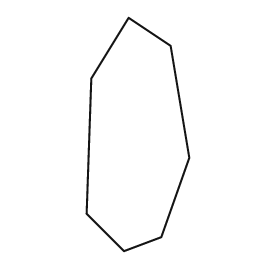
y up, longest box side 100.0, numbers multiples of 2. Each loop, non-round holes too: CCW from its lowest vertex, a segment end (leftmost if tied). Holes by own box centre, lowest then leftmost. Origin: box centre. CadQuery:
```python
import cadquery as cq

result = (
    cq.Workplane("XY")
    .moveTo(-6.0, -50.0)
    .lineTo(10.0, -44.0)
    .lineTo(22.0, -10.0)
    .lineTo(14.0, 38.0)
    .lineTo(-4.0, 50.0)
    .lineTo(-20.0, 24.0)
    .lineTo(-22.0, -34.0)
    .close()
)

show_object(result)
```